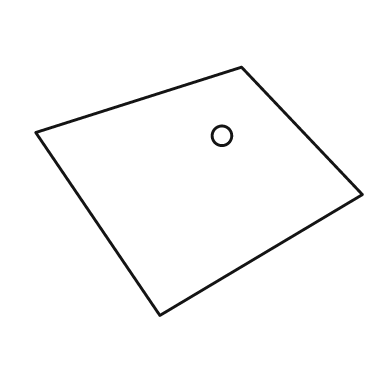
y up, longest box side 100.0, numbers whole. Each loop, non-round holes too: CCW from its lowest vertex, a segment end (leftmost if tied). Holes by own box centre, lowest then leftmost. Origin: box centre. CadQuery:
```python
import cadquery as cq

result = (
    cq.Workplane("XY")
    .moveTo(-12.0, -38.0)
    .lineTo(50.0, -1.0)
    .lineTo(13.0, 38.0)
    .lineTo(-50.0, 18.0)
    .close()
    .moveTo(7.0, 17.0)
    .circle(3.0)
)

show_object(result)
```